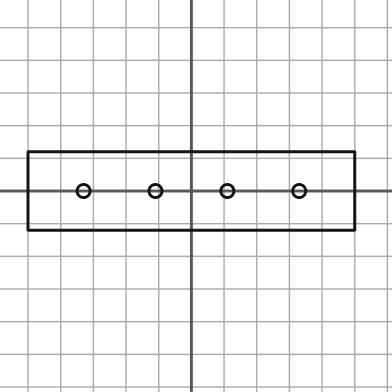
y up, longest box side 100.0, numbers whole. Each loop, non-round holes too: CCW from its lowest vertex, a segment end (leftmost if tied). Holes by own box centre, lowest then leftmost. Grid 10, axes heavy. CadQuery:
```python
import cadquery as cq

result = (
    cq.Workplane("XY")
    .moveTo(-50.0, -12.0)
    .lineTo(50.0, -12.0)
    .lineTo(50.0, 12.0)
    .lineTo(-50.0, 12.0)
    .close()
    .moveTo(-33.0, 0.0)
    .circle(2.0)
    .moveTo(-11.0, 0.0)
    .circle(2.0)
    .moveTo(11.0, 0.0)
    .circle(2.0)
    .moveTo(33.0, 0.0)
    .circle(2.0)
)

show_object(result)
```